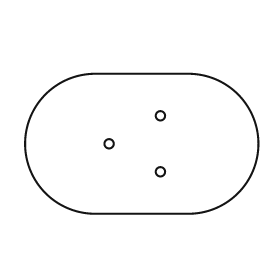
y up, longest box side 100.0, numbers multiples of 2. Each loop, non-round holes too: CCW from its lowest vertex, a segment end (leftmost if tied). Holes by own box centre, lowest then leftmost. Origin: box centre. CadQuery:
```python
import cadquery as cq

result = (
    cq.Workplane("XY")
    .moveTo(-20.0, -30.0)
    .lineTo(20.0, -30.0)
    .threePointArc((50.0, 0.0), (20.0, 30.0))
    .lineTo(-20.0, 30.0)
    .threePointArc((-50.0, 0.0), (-20.0, -30.0))
    .close()
    .moveTo(8.0, -12.0)
    .circle(2.0)
    .moveTo(-14.0, 0.0)
    .circle(2.0)
    .moveTo(8.0, 12.0)
    .circle(2.0)
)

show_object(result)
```